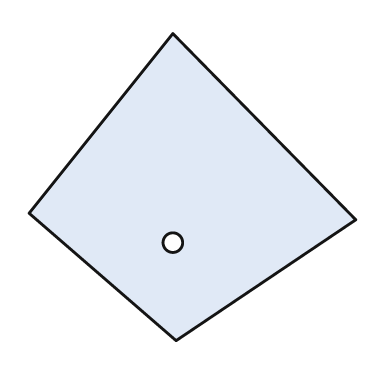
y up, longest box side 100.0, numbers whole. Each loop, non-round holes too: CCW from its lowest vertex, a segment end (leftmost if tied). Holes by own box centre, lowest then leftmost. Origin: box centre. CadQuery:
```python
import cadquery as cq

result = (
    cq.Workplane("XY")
    .moveTo(-5.0, -47.0)
    .lineTo(50.0, -10.0)
    .lineTo(-6.0, 47.0)
    .lineTo(-50.0, -8.0)
    .close()
    .moveTo(-6.0, -17.0)
    .circle(3.0)
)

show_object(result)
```